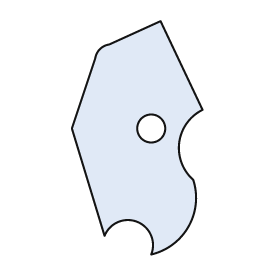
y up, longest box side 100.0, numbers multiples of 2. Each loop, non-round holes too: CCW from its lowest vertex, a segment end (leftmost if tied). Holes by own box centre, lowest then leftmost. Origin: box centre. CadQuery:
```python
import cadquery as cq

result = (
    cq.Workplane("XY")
    .moveTo(6.0, -50.0)
    .threePointArc((22.0, -38.0), (24.0, -18.0))
    .threePointArc((18.0, -2.0), (28.0, 12.0))
    .lineTo(10.0, 50.0)
    .lineTo(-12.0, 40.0)
    .threePointArc((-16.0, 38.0), (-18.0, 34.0))
    .lineTo(-28.0, 4.0)
    .lineTo(-14.0, -42.0)
    .threePointArc((0.0, -36.0), (6.0, -50.0))
    .close()
    .moveTo(6.0, 4.0)
    .circle(6.0)
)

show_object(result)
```